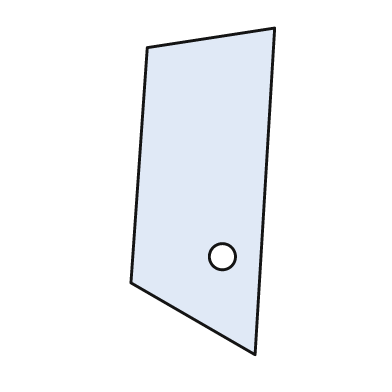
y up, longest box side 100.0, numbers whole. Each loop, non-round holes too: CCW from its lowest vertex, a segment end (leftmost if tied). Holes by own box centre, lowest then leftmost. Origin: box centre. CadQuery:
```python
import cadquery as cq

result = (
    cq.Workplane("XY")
    .moveTo(16.0, -50.0)
    .lineTo(22.0, 50.0)
    .lineTo(-17.0, 44.0)
    .lineTo(-22.0, -28.0)
    .close()
    .moveTo(6.0, -20.0)
    .circle(4.0)
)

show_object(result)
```